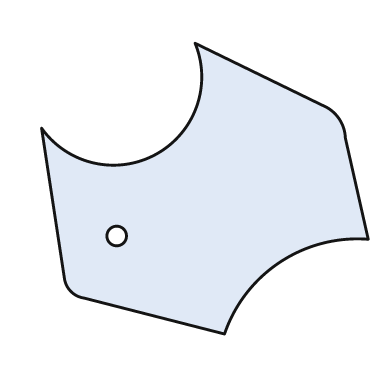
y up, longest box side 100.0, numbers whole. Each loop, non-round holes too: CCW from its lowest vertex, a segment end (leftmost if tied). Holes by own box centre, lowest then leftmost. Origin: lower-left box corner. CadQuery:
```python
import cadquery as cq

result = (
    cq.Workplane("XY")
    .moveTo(56.0, 0.0)
    .threePointArc((73.0, 22.0), (100.0, 29.0))
    .lineTo(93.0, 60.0)
    .threePointArc((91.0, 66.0), (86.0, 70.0))
    .lineTo(47.0, 89.0)
    .threePointArc((35.0, 55.0), (0.0, 63.0))
    .lineTo(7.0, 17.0)
    .threePointArc((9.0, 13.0), (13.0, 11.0))
    .close()
    .moveTo(23.0, 30.0)
    .circle(3.0)
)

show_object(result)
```